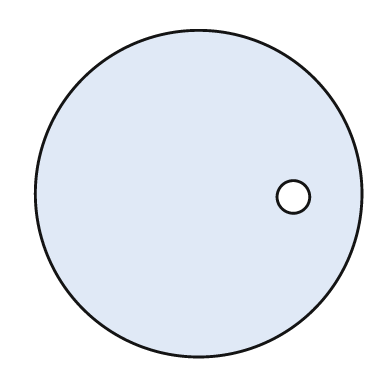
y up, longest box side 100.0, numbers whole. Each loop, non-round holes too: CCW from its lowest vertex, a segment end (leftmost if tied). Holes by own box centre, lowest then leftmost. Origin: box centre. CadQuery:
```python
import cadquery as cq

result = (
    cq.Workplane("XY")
    .moveTo(0.0, 0.0)
    .circle(50.0)
    .moveTo(29.0, -1.0)
    .circle(5.0)
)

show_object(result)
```